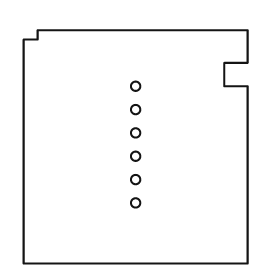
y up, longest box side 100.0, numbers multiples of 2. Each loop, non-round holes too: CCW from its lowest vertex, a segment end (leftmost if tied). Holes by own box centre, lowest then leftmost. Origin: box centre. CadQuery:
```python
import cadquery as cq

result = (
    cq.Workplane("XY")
    .moveTo(-48.0, -50.0)
    .lineTo(48.0, -50.0)
    .lineTo(48.0, 26.0)
    .lineTo(38.0, 26.0)
    .lineTo(38.0, 36.0)
    .lineTo(48.0, 36.0)
    .lineTo(48.0, 50.0)
    .lineTo(-42.0, 50.0)
    .lineTo(-42.0, 46.0)
    .lineTo(-48.0, 46.0)
    .close()
    .moveTo(0.0, -24.0)
    .circle(2.0)
    .moveTo(0.0, -14.0)
    .circle(2.0)
    .moveTo(0.0, -4.0)
    .circle(2.0)
    .moveTo(0.0, 6.0)
    .circle(2.0)
    .moveTo(0.0, 16.0)
    .circle(2.0)
    .moveTo(0.0, 26.0)
    .circle(2.0)
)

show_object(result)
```